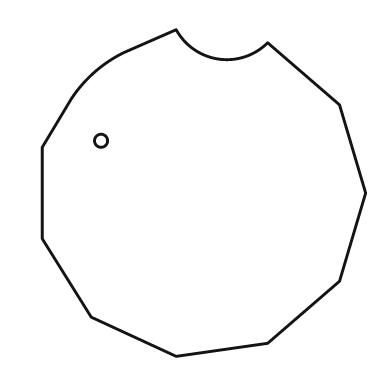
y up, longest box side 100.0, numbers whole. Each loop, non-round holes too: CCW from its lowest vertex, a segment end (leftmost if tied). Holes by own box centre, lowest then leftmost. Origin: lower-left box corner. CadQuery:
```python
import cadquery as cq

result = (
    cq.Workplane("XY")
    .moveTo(41.0, 0.0)
    .lineTo(69.0, 4.0)
    .lineTo(91.0, 23.0)
    .lineTo(99.0, 50.0)
    .lineTo(91.0, 77.0)
    .lineTo(69.0, 96.0)
    .threePointArc((54.0, 91.0), (41.0, 100.0))
    .lineTo(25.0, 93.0)
    .threePointArc((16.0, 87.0), (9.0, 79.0))
    .lineTo(0.0, 64.0)
    .lineTo(0.0, 36.0)
    .lineTo(15.0, 12.0)
    .close()
    .moveTo(18.0, 66.0)
    .circle(2.0)
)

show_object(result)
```